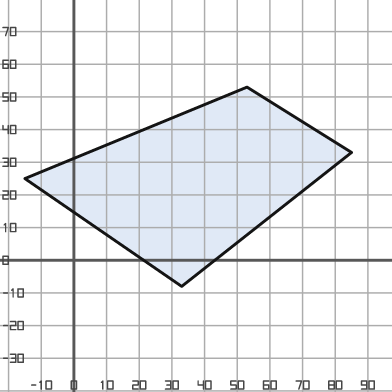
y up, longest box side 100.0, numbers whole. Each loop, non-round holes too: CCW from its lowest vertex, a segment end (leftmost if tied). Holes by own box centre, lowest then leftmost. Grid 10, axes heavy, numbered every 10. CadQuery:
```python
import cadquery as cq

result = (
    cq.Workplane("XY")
    .moveTo(33.0, -8.0)
    .lineTo(85.0, 33.0)
    .lineTo(53.0, 53.0)
    .lineTo(-15.0, 25.0)
    .close()
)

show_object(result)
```